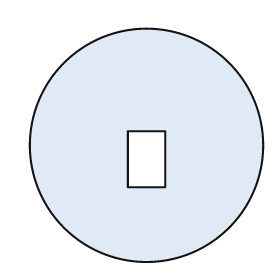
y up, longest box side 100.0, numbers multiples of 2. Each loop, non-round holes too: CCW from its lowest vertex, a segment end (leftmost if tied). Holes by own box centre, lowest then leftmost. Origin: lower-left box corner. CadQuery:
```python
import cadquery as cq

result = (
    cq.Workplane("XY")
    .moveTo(50.0, 50.0)
    .circle(50.0)
    .moveTo(42.0, 32.0)
    .lineTo(58.0, 32.0)
    .lineTo(58.0, 56.0)
    .lineTo(42.0, 56.0)
    .close()
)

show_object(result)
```